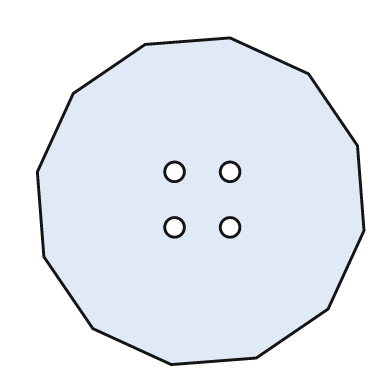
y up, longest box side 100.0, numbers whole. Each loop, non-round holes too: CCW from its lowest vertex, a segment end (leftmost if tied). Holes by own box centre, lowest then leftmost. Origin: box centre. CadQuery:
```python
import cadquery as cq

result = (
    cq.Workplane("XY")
    .moveTo(-9.0, -50.0)
    .lineTo(17.0, -48.0)
    .lineTo(39.0, -33.0)
    .lineTo(50.0, -9.0)
    .lineTo(48.0, 17.0)
    .lineTo(33.0, 39.0)
    .lineTo(9.0, 50.0)
    .lineTo(-17.0, 48.0)
    .lineTo(-39.0, 33.0)
    .lineTo(-50.0, 9.0)
    .lineTo(-48.0, -17.0)
    .lineTo(-33.0, -39.0)
    .close()
    .moveTo(-8.0, -8.0)
    .circle(3.0)
    .moveTo(9.0, -8.0)
    .circle(3.0)
    .moveTo(-8.0, 9.0)
    .circle(3.0)
    .moveTo(9.0, 9.0)
    .circle(3.0)
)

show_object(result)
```